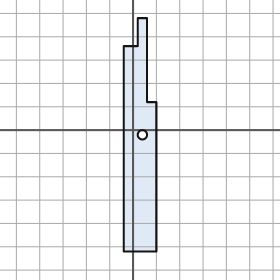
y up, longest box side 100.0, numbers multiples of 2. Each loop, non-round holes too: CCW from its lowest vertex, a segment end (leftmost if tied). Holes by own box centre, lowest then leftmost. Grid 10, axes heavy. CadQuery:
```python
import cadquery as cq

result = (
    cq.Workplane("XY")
    .moveTo(-4.0, -52.0)
    .lineTo(10.0, -52.0)
    .lineTo(10.0, 12.0)
    .lineTo(6.0, 12.0)
    .lineTo(6.0, 48.0)
    .lineTo(2.0, 48.0)
    .lineTo(2.0, 36.0)
    .lineTo(-4.0, 36.0)
    .close()
    .moveTo(4.0, -2.0)
    .circle(2.0)
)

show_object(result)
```